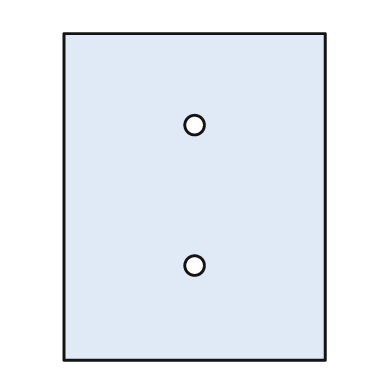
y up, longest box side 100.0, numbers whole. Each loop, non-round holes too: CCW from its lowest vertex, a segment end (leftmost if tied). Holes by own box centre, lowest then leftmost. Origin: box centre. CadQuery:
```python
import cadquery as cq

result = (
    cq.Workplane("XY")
    .moveTo(-40.0, -50.0)
    .lineTo(40.0, -50.0)
    .lineTo(40.0, 50.0)
    .lineTo(-40.0, 50.0)
    .close()
    .moveTo(0.0, -21.0)
    .circle(3.0)
    .moveTo(0.0, 22.0)
    .circle(3.0)
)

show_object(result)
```